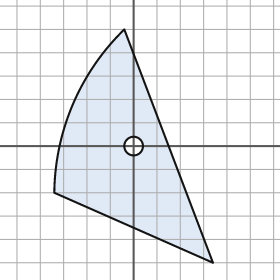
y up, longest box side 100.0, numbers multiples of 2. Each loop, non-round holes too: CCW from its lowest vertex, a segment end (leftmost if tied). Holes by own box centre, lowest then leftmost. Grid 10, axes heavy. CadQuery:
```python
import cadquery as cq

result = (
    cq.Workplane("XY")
    .moveTo(34.0, -50.0)
    .lineTo(-4.0, 50.0)
    .threePointArc((-26.0, 18.0), (-34.0, -20.0))
    .close()
    .moveTo(0.0, 0.0)
    .circle(4.0)
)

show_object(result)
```